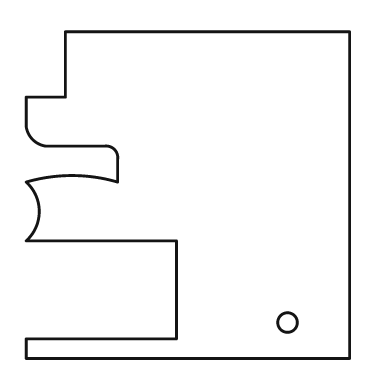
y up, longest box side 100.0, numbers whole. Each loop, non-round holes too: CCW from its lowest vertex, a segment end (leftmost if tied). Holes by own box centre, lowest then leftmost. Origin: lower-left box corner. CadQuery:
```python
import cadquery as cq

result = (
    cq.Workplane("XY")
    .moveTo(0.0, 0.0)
    .lineTo(99.0, 0.0)
    .lineTo(99.0, 100.0)
    .lineTo(12.0, 100.0)
    .lineTo(12.0, 80.0)
    .lineTo(0.0, 80.0)
    .lineTo(0.0, 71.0)
    .threePointArc((2.0, 67.0), (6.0, 65.0))
    .lineTo(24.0, 65.0)
    .threePointArc((27.0, 64.0), (28.0, 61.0))
    .lineTo(28.0, 54.0)
    .threePointArc((14.0, 56.0), (0.0, 54.0))
    .threePointArc((4.0, 45.0), (0.0, 36.0))
    .lineTo(46.0, 36.0)
    .lineTo(46.0, 6.0)
    .lineTo(0.0, 6.0)
    .close()
    .moveTo(80.0, 11.0)
    .circle(3.0)
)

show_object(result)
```